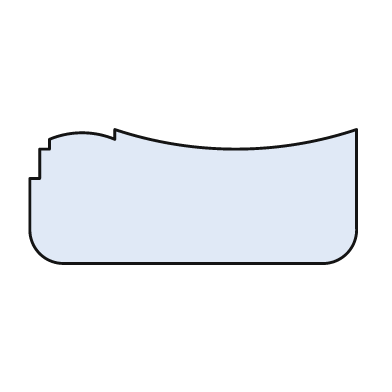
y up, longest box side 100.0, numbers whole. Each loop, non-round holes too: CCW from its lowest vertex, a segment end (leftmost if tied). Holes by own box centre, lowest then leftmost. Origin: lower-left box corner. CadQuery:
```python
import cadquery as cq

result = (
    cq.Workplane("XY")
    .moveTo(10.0, 0.0)
    .lineTo(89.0, 0.0)
    .threePointArc((97.0, 3.0), (100.0, 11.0))
    .lineTo(100.0, 41.0)
    .threePointArc((63.0, 35.0), (26.0, 41.0))
    .lineTo(26.0, 38.0)
    .threePointArc((16.0, 40.0), (6.0, 38.0))
    .lineTo(6.0, 35.0)
    .lineTo(3.0, 35.0)
    .lineTo(3.0, 26.0)
    .lineTo(0.0, 26.0)
    .lineTo(0.0, 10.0)
    .threePointArc((3.0, 3.0), (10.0, 0.0))
    .close()
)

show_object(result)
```